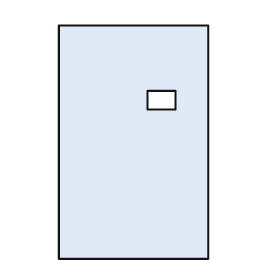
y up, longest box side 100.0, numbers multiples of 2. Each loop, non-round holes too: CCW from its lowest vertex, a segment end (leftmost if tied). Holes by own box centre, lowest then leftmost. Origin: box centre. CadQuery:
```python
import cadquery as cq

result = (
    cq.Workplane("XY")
    .moveTo(-32.0, -50.0)
    .lineTo(32.0, -50.0)
    .lineTo(32.0, 50.0)
    .lineTo(-32.0, 50.0)
    .close()
    .moveTo(6.0, 14.0)
    .lineTo(18.0, 14.0)
    .lineTo(18.0, 22.0)
    .lineTo(6.0, 22.0)
    .close()
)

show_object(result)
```